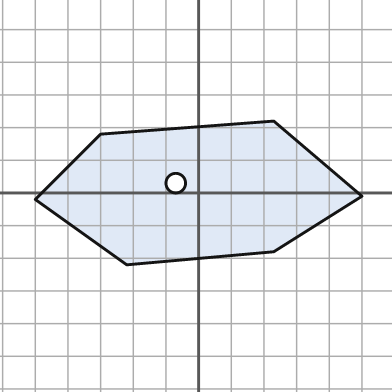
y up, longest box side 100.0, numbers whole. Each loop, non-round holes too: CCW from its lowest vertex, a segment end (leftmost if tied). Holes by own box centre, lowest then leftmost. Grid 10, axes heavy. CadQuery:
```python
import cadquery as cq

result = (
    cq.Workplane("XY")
    .moveTo(-22.0, -22.0)
    .lineTo(23.0, -18.0)
    .lineTo(50.0, -1.0)
    .lineTo(23.0, 22.0)
    .lineTo(-30.0, 18.0)
    .lineTo(-50.0, -2.0)
    .close()
    .moveTo(-7.0, 3.0)
    .circle(3.0)
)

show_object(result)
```